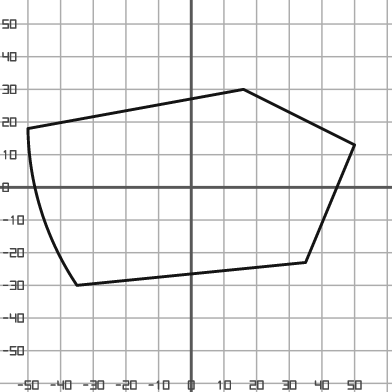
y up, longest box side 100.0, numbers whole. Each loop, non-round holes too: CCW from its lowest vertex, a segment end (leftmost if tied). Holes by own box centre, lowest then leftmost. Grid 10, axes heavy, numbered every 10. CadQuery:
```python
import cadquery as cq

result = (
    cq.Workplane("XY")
    .moveTo(-35.0, -30.0)
    .lineTo(35.0, -23.0)
    .lineTo(50.0, 13.0)
    .lineTo(16.0, 30.0)
    .lineTo(-50.0, 18.0)
    .threePointArc((-46.0, -7.0), (-35.0, -30.0))
    .close()
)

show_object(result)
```